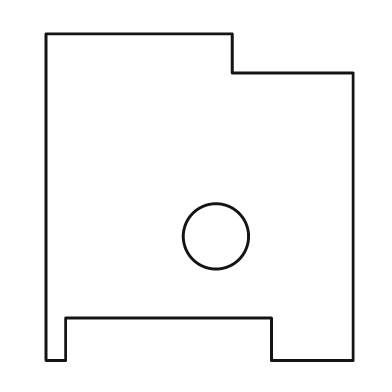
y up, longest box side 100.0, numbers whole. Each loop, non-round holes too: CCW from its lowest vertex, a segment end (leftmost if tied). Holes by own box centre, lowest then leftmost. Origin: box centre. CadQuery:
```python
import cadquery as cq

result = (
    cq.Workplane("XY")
    .moveTo(-47.0, -50.0)
    .lineTo(-41.0, -50.0)
    .lineTo(-41.0, -37.0)
    .lineTo(22.0, -37.0)
    .lineTo(22.0, -50.0)
    .lineTo(47.0, -50.0)
    .lineTo(47.0, 38.0)
    .lineTo(10.0, 38.0)
    .lineTo(10.0, 50.0)
    .lineTo(-47.0, 50.0)
    .close()
    .moveTo(5.0, -12.0)
    .circle(10.0)
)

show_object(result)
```